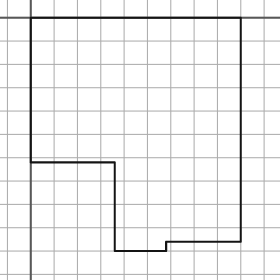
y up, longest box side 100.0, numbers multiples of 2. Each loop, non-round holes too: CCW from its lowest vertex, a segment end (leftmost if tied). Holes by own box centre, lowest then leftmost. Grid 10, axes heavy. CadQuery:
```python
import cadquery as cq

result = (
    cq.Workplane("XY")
    .moveTo(36.0, -100.0)
    .lineTo(58.0, -100.0)
    .lineTo(58.0, -96.0)
    .lineTo(90.0, -96.0)
    .lineTo(90.0, 0.0)
    .lineTo(0.0, 0.0)
    .lineTo(0.0, -62.0)
    .lineTo(36.0, -62.0)
    .close()
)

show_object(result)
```